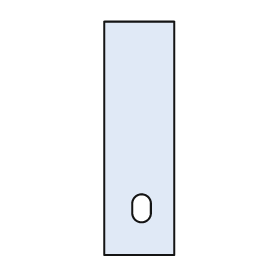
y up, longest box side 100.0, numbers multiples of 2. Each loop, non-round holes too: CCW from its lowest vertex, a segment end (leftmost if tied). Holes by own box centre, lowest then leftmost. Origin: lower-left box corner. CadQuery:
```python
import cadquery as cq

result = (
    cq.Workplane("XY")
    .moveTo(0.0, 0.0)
    .lineTo(30.0, 0.0)
    .lineTo(30.0, 100.0)
    .lineTo(0.0, 100.0)
    .close()
    .moveTo(12.0, 18.0)
    .threePointArc((16.0, 14.0), (20.0, 18.0))
    .lineTo(20.0, 22.0)
    .threePointArc((16.0, 26.0), (12.0, 22.0))
    .close()
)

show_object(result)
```